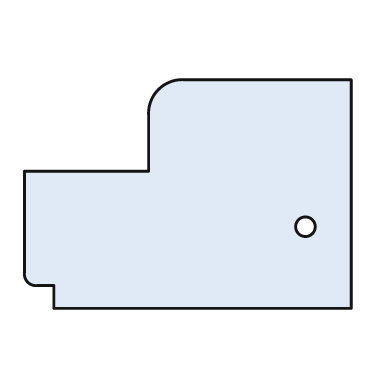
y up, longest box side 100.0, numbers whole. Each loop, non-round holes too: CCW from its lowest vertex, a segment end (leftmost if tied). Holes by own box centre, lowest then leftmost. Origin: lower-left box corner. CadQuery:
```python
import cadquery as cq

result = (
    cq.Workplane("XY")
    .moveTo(9.0, 0.0)
    .lineTo(100.0, 0.0)
    .lineTo(100.0, 70.0)
    .lineTo(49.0, 70.0)
    .threePointArc((41.0, 67.0), (38.0, 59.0))
    .lineTo(38.0, 42.0)
    .lineTo(0.0, 42.0)
    .lineTo(0.0, 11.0)
    .threePointArc((1.0, 8.0), (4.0, 7.0))
    .lineTo(9.0, 7.0)
    .close()
    .moveTo(86.0, 25.0)
    .circle(3.0)
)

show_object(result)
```